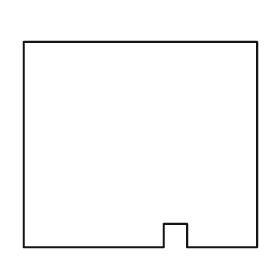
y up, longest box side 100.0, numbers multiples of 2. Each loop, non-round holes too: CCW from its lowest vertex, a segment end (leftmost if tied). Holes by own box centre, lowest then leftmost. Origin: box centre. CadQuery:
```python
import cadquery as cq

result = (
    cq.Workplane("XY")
    .moveTo(-50.0, -44.0)
    .lineTo(10.0, -44.0)
    .lineTo(10.0, -34.0)
    .lineTo(20.0, -34.0)
    .lineTo(20.0, -44.0)
    .lineTo(50.0, -44.0)
    .lineTo(50.0, 44.0)
    .lineTo(-50.0, 44.0)
    .close()
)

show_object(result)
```